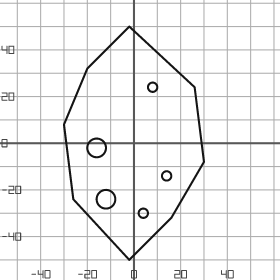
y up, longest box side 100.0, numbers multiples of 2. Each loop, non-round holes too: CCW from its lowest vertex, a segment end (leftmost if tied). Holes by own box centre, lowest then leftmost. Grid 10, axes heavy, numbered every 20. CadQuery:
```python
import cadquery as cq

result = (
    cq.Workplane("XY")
    .moveTo(-2.0, -50.0)
    .lineTo(16.0, -32.0)
    .lineTo(30.0, -8.0)
    .lineTo(26.0, 24.0)
    .lineTo(-2.0, 50.0)
    .lineTo(-20.0, 32.0)
    .lineTo(-30.0, 8.0)
    .lineTo(-26.0, -24.0)
    .close()
    .moveTo(4.0, -30.0)
    .circle(2.0)
    .moveTo(-12.0, -24.0)
    .circle(4.0)
    .moveTo(14.0, -14.0)
    .circle(2.0)
    .moveTo(-16.0, -2.0)
    .circle(4.0)
    .moveTo(8.0, 24.0)
    .circle(2.0)
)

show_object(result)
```